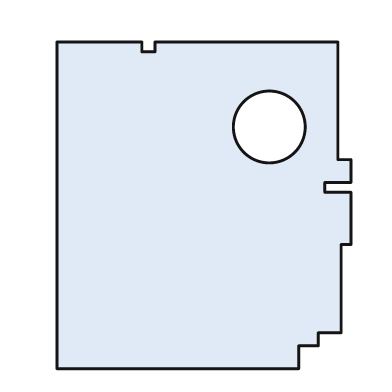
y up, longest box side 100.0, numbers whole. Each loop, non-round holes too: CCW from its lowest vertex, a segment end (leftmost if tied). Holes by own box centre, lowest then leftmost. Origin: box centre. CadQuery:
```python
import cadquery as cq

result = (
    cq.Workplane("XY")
    .moveTo(-45.0, -50.0)
    .lineTo(29.0, -50.0)
    .lineTo(29.0, -43.0)
    .lineTo(35.0, -43.0)
    .lineTo(35.0, -39.0)
    .lineTo(42.0, -39.0)
    .lineTo(42.0, -12.0)
    .lineTo(45.0, -12.0)
    .lineTo(45.0, 4.0)
    .lineTo(37.0, 4.0)
    .lineTo(37.0, 7.0)
    .lineTo(45.0, 7.0)
    .lineTo(45.0, 14.0)
    .lineTo(41.0, 14.0)
    .lineTo(41.0, 50.0)
    .lineTo(-15.0, 50.0)
    .lineTo(-15.0, 47.0)
    .lineTo(-19.0, 47.0)
    .lineTo(-19.0, 50.0)
    .lineTo(-45.0, 50.0)
    .close()
    .moveTo(20.0, 24.0)
    .circle(11.0)
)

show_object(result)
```